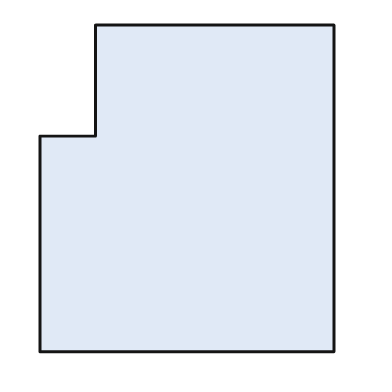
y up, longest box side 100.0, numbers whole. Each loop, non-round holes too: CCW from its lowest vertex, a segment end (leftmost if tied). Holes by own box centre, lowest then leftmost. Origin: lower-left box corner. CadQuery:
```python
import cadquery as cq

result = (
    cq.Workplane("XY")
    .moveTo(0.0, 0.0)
    .lineTo(90.0, 0.0)
    .lineTo(90.0, 100.0)
    .lineTo(17.0, 100.0)
    .lineTo(17.0, 66.0)
    .lineTo(0.0, 66.0)
    .close()
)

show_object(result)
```